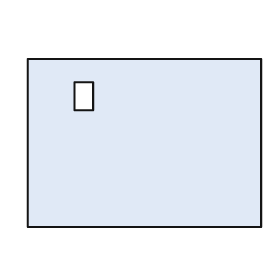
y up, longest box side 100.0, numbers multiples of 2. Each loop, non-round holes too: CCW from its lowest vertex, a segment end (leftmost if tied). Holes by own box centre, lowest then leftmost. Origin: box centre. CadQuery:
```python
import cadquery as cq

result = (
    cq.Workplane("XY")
    .moveTo(-50.0, -36.0)
    .lineTo(50.0, -36.0)
    .lineTo(50.0, 36.0)
    .lineTo(-50.0, 36.0)
    .close()
    .moveTo(-30.0, 14.0)
    .lineTo(-22.0, 14.0)
    .lineTo(-22.0, 26.0)
    .lineTo(-30.0, 26.0)
    .close()
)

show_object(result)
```